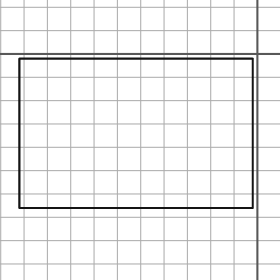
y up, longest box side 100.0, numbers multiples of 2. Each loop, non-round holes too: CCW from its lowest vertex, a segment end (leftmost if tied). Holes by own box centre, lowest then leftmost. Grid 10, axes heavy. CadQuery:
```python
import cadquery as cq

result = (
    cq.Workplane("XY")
    .moveTo(-102.0, -66.0)
    .lineTo(-2.0, -66.0)
    .lineTo(-2.0, -2.0)
    .lineTo(-102.0, -2.0)
    .close()
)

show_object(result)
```